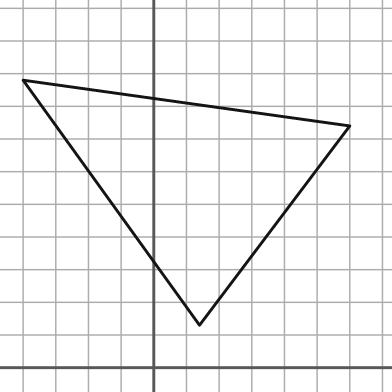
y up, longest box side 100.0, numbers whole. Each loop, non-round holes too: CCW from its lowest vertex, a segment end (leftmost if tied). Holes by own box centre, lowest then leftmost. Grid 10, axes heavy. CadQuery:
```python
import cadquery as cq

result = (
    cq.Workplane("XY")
    .moveTo(14.0, 13.0)
    .lineTo(60.0, 74.0)
    .lineTo(-40.0, 88.0)
    .close()
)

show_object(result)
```